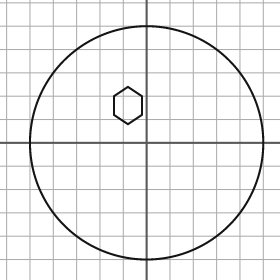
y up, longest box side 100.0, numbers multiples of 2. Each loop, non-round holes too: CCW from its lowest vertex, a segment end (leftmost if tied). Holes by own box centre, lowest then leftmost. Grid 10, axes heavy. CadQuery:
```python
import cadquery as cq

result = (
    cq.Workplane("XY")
    .moveTo(0.0, 0.0)
    .circle(50.0)
    .moveTo(-8.0, 8.0)
    .lineTo(-2.0, 12.0)
    .lineTo(-2.0, 20.0)
    .lineTo(-8.0, 24.0)
    .lineTo(-14.0, 20.0)
    .lineTo(-14.0, 12.0)
    .close()
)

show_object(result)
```